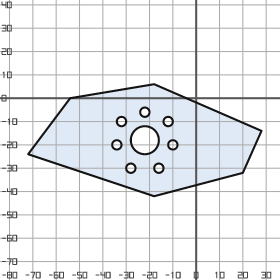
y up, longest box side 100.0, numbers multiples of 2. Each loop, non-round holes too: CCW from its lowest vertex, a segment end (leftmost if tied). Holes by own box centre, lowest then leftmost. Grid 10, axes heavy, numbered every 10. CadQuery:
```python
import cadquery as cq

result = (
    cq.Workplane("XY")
    .moveTo(-18.0, -42.0)
    .lineTo(20.0, -32.0)
    .lineTo(28.0, -14.0)
    .lineTo(-18.0, 6.0)
    .lineTo(-54.0, 0.0)
    .lineTo(-72.0, -24.0)
    .close()
    .moveTo(-28.0, -30.0)
    .circle(2.0)
    .moveTo(-16.0, -30.0)
    .circle(2.0)
    .moveTo(-34.0, -20.0)
    .circle(2.0)
    .moveTo(-10.0, -20.0)
    .circle(2.0)
    .moveTo(-22.0, -18.0)
    .circle(6.0)
    .moveTo(-32.0, -10.0)
    .circle(2.0)
    .moveTo(-12.0, -10.0)
    .circle(2.0)
    .moveTo(-22.0, -6.0)
    .circle(2.0)
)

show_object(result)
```